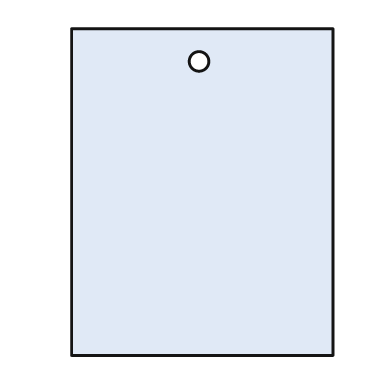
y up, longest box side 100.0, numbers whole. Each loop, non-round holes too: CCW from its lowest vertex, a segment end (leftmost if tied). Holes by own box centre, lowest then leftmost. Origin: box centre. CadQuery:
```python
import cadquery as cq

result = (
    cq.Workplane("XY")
    .moveTo(-40.0, -50.0)
    .lineTo(40.0, -50.0)
    .lineTo(40.0, 50.0)
    .lineTo(-40.0, 50.0)
    .close()
    .moveTo(-1.0, 40.0)
    .circle(3.0)
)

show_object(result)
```